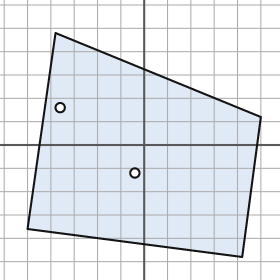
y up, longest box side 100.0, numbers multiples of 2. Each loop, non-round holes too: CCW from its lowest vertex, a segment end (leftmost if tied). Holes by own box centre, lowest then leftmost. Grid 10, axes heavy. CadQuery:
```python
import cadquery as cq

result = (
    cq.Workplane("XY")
    .moveTo(42.0, -48.0)
    .lineTo(50.0, 12.0)
    .lineTo(-38.0, 48.0)
    .lineTo(-50.0, -36.0)
    .close()
    .moveTo(-4.0, -12.0)
    .circle(2.0)
    .moveTo(-36.0, 16.0)
    .circle(2.0)
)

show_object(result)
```